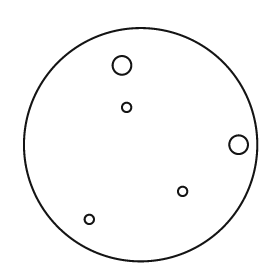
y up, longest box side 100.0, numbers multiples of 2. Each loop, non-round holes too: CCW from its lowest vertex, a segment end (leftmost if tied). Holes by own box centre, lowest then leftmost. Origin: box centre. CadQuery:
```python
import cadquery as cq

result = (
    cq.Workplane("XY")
    .moveTo(0.0, 0.0)
    .circle(50.0)
    .moveTo(-22.0, -32.0)
    .circle(2.0)
    .moveTo(18.0, -20.0)
    .circle(2.0)
    .moveTo(42.0, 0.0)
    .circle(4.0)
    .moveTo(-6.0, 16.0)
    .circle(2.0)
    .moveTo(-8.0, 34.0)
    .circle(4.0)
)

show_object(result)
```